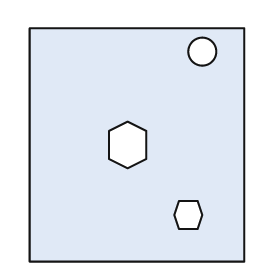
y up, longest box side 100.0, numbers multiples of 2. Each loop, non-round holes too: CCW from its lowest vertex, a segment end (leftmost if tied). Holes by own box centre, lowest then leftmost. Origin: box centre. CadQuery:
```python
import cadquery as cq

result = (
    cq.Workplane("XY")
    .moveTo(-46.0, -50.0)
    .lineTo(46.0, -50.0)
    .lineTo(46.0, 50.0)
    .lineTo(-46.0, 50.0)
    .close()
    .moveTo(18.0, -36.0)
    .lineTo(26.0, -36.0)
    .lineTo(28.0, -30.0)
    .lineTo(26.0, -24.0)
    .lineTo(18.0, -24.0)
    .lineTo(16.0, -30.0)
    .close()
    .moveTo(-4.0, -10.0)
    .lineTo(4.0, -6.0)
    .lineTo(4.0, 6.0)
    .lineTo(-4.0, 10.0)
    .lineTo(-12.0, 6.0)
    .lineTo(-12.0, -6.0)
    .close()
    .moveTo(28.0, 40.0)
    .circle(6.0)
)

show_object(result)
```